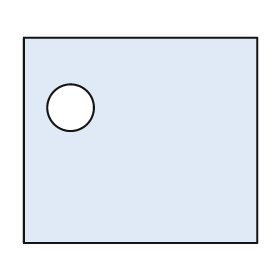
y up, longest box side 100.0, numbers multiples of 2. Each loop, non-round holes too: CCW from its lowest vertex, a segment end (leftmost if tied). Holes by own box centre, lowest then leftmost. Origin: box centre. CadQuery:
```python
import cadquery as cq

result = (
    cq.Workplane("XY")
    .moveTo(-50.0, -44.0)
    .lineTo(50.0, -44.0)
    .lineTo(50.0, 44.0)
    .lineTo(-50.0, 44.0)
    .close()
    .moveTo(-30.0, 14.0)
    .circle(10.0)
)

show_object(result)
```